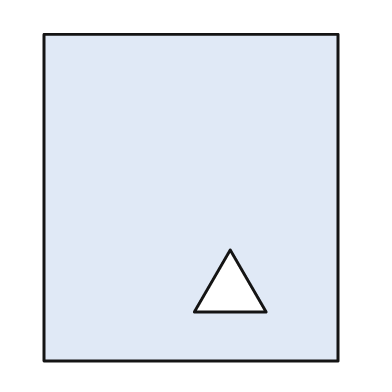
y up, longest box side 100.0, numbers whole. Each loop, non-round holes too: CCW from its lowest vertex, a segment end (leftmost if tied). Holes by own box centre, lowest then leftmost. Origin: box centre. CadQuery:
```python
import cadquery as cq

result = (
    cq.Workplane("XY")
    .moveTo(-45.0, -50.0)
    .lineTo(45.0, -50.0)
    .lineTo(45.0, 50.0)
    .lineTo(-45.0, 50.0)
    .close()
    .moveTo(1.0, -35.0)
    .lineTo(23.0, -35.0)
    .lineTo(12.0, -16.0)
    .close()
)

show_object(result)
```